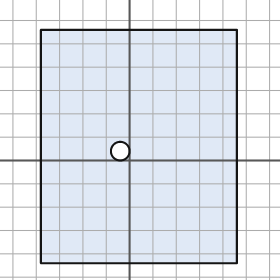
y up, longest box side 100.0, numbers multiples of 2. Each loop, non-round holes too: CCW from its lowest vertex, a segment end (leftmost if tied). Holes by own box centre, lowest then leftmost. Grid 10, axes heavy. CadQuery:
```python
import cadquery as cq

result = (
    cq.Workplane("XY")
    .moveTo(-38.0, -44.0)
    .lineTo(46.0, -44.0)
    .lineTo(46.0, 56.0)
    .lineTo(-38.0, 56.0)
    .close()
    .moveTo(-4.0, 4.0)
    .circle(4.0)
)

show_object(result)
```